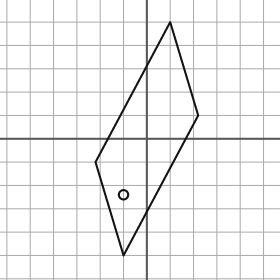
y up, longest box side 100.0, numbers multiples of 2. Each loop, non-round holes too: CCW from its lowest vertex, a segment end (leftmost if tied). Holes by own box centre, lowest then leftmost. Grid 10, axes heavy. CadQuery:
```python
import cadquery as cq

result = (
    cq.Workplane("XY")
    .moveTo(-10.0, -50.0)
    .lineTo(22.0, 10.0)
    .lineTo(10.0, 50.0)
    .lineTo(-22.0, -10.0)
    .close()
    .moveTo(-10.0, -24.0)
    .circle(2.0)
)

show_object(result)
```